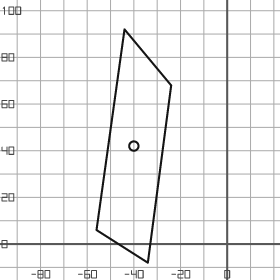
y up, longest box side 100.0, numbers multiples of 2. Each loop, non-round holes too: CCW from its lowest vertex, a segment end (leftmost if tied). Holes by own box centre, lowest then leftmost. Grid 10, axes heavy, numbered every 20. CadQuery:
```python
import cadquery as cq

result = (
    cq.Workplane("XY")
    .moveTo(-34.0, -8.0)
    .lineTo(-24.0, 68.0)
    .lineTo(-44.0, 92.0)
    .lineTo(-56.0, 6.0)
    .close()
    .moveTo(-40.0, 42.0)
    .circle(2.0)
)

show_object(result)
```